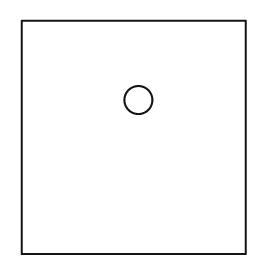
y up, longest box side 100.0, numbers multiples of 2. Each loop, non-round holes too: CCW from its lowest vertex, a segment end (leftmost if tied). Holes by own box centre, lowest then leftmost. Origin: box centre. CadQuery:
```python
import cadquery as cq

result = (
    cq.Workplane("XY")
    .moveTo(-48.0, -50.0)
    .lineTo(48.0, -50.0)
    .lineTo(48.0, 50.0)
    .lineTo(-48.0, 50.0)
    .close()
    .moveTo(2.0, 16.0)
    .circle(6.0)
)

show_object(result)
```